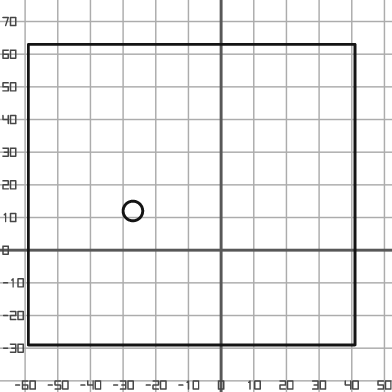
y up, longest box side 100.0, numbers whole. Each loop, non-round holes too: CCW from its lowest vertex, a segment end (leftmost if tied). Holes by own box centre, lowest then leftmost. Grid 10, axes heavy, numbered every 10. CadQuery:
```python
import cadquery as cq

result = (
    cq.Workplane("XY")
    .moveTo(-59.0, -29.0)
    .lineTo(41.0, -29.0)
    .lineTo(41.0, 63.0)
    .lineTo(-59.0, 63.0)
    .close()
    .moveTo(-27.0, 12.0)
    .circle(3.0)
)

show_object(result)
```